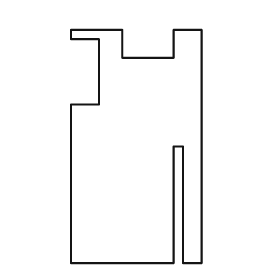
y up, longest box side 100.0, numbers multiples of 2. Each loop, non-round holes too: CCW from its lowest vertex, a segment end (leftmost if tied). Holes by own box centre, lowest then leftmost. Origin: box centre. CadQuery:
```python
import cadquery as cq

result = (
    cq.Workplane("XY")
    .moveTo(-28.0, -50.0)
    .lineTo(16.0, -50.0)
    .lineTo(16.0, 0.0)
    .lineTo(20.0, 0.0)
    .lineTo(20.0, -50.0)
    .lineTo(28.0, -50.0)
    .lineTo(28.0, 50.0)
    .lineTo(16.0, 50.0)
    .lineTo(16.0, 38.0)
    .lineTo(-6.0, 38.0)
    .lineTo(-6.0, 50.0)
    .lineTo(-28.0, 50.0)
    .lineTo(-28.0, 46.0)
    .lineTo(-16.0, 46.0)
    .lineTo(-16.0, 18.0)
    .lineTo(-28.0, 18.0)
    .close()
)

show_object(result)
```